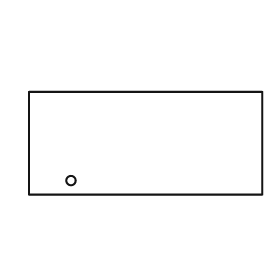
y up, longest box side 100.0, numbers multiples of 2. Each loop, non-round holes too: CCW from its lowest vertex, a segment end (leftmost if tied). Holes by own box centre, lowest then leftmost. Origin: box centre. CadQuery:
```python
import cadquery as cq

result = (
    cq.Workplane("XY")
    .moveTo(-50.0, -22.0)
    .lineTo(50.0, -22.0)
    .lineTo(50.0, 22.0)
    .lineTo(-50.0, 22.0)
    .close()
    .moveTo(-32.0, -16.0)
    .circle(2.0)
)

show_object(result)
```